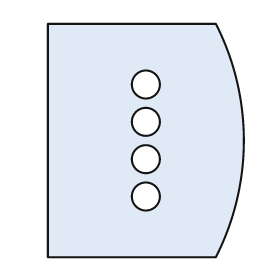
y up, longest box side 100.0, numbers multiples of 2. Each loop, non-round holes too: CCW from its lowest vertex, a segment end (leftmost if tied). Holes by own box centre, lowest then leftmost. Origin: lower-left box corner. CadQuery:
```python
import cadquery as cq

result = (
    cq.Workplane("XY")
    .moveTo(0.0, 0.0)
    .lineTo(72.0, 0.0)
    .threePointArc((84.0, 50.0), (72.0, 100.0))
    .lineTo(0.0, 100.0)
    .close()
    .moveTo(42.0, 26.0)
    .circle(6.0)
    .moveTo(42.0, 42.0)
    .circle(6.0)
    .moveTo(42.0, 58.0)
    .circle(6.0)
    .moveTo(42.0, 74.0)
    .circle(6.0)
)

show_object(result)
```